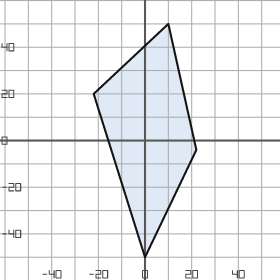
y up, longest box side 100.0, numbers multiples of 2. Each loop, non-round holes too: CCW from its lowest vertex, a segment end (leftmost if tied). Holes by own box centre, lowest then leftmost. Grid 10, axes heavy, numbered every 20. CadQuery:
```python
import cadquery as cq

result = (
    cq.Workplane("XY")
    .moveTo(0.0, -50.0)
    .lineTo(22.0, -4.0)
    .lineTo(10.0, 50.0)
    .lineTo(-22.0, 20.0)
    .close()
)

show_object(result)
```